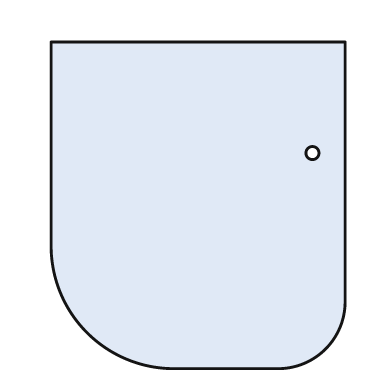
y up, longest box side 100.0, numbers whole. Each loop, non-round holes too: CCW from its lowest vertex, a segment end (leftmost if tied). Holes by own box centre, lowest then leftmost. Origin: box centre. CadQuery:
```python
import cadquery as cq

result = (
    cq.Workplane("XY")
    .moveTo(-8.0, -50.0)
    .lineTo(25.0, -50.0)
    .threePointArc((39.0, -44.0), (45.0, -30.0))
    .lineTo(45.0, 50.0)
    .lineTo(-45.0, 50.0)
    .lineTo(-45.0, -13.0)
    .threePointArc((-34.0, -39.0), (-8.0, -50.0))
    .close()
    .moveTo(35.0, 16.0)
    .circle(2.0)
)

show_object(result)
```